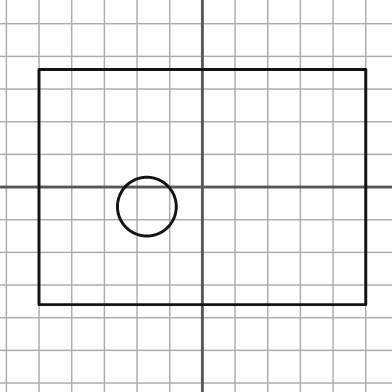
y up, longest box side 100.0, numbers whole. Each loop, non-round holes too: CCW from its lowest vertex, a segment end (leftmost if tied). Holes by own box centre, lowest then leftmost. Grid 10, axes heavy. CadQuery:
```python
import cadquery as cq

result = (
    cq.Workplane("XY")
    .moveTo(-50.0, -36.0)
    .lineTo(50.0, -36.0)
    .lineTo(50.0, 36.0)
    .lineTo(-50.0, 36.0)
    .close()
    .moveTo(-17.0, -6.0)
    .circle(9.0)
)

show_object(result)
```